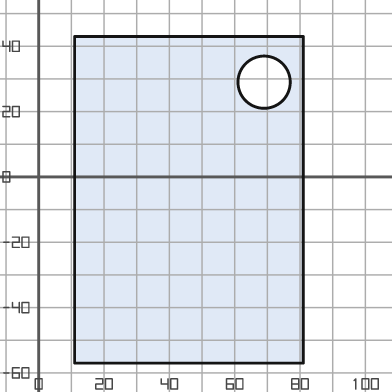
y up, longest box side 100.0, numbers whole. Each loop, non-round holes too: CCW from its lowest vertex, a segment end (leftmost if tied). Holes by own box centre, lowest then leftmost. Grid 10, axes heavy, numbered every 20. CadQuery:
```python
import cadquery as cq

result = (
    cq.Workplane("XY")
    .moveTo(11.0, -57.0)
    .lineTo(81.0, -57.0)
    .lineTo(81.0, 43.0)
    .lineTo(11.0, 43.0)
    .close()
    .moveTo(69.0, 29.0)
    .circle(8.0)
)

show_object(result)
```